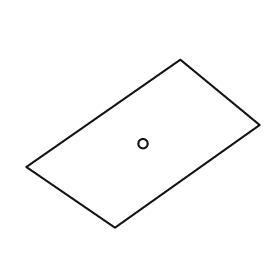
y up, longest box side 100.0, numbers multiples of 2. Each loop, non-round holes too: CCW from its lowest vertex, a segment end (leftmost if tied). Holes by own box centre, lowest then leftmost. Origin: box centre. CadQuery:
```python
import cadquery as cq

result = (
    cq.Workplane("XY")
    .moveTo(-12.0, -36.0)
    .lineTo(50.0, 8.0)
    .lineTo(16.0, 36.0)
    .lineTo(-50.0, -10.0)
    .close()
    .moveTo(0.0, 0.0)
    .circle(2.0)
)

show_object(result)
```